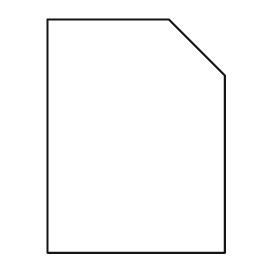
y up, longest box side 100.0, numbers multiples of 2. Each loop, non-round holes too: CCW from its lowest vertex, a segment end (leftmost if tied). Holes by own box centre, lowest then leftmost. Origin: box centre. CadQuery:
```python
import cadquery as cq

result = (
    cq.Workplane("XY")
    .moveTo(-38.0, -50.0)
    .lineTo(38.0, -50.0)
    .lineTo(38.0, 26.0)
    .lineTo(14.0, 50.0)
    .lineTo(-38.0, 50.0)
    .close()
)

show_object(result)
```